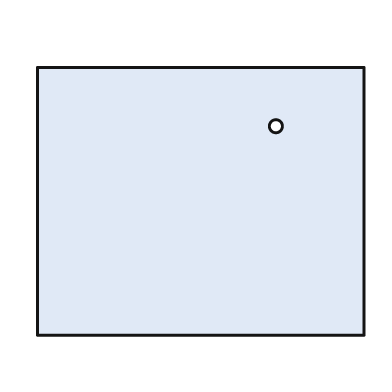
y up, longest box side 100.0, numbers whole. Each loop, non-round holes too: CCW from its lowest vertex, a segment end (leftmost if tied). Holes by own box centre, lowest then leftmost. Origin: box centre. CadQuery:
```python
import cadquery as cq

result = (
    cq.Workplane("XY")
    .moveTo(-50.0, -41.0)
    .lineTo(50.0, -41.0)
    .lineTo(50.0, 41.0)
    .lineTo(-50.0, 41.0)
    .close()
    .moveTo(23.0, 23.0)
    .circle(2.0)
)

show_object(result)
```